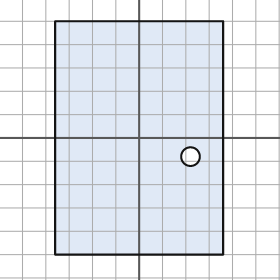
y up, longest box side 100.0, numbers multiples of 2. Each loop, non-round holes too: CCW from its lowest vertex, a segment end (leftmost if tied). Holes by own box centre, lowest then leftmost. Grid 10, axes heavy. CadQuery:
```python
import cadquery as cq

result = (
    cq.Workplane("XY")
    .moveTo(-36.0, -50.0)
    .lineTo(36.0, -50.0)
    .lineTo(36.0, 50.0)
    .lineTo(-36.0, 50.0)
    .close()
    .moveTo(22.0, -8.0)
    .circle(4.0)
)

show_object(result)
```